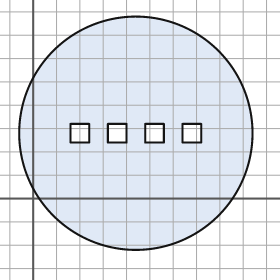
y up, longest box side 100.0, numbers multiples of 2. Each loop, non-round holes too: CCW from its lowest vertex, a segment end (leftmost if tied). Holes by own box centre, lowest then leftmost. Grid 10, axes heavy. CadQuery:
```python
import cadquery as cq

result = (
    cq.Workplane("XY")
    .moveTo(44.0, 28.0)
    .circle(50.0)
    .moveTo(16.0, 24.0)
    .lineTo(24.0, 24.0)
    .lineTo(24.0, 32.0)
    .lineTo(16.0, 32.0)
    .close()
    .moveTo(32.0, 24.0)
    .lineTo(40.0, 24.0)
    .lineTo(40.0, 32.0)
    .lineTo(32.0, 32.0)
    .close()
    .moveTo(48.0, 24.0)
    .lineTo(56.0, 24.0)
    .lineTo(56.0, 32.0)
    .lineTo(48.0, 32.0)
    .close()
    .moveTo(64.0, 24.0)
    .lineTo(72.0, 24.0)
    .lineTo(72.0, 32.0)
    .lineTo(64.0, 32.0)
    .close()
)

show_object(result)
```